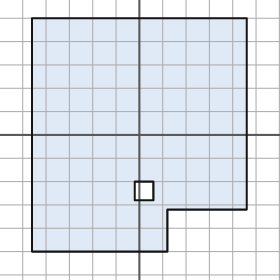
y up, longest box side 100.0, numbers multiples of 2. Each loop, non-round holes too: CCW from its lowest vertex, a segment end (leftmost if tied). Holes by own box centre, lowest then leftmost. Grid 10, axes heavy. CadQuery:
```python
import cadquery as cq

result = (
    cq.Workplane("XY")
    .moveTo(-46.0, -50.0)
    .lineTo(12.0, -50.0)
    .lineTo(12.0, -32.0)
    .lineTo(46.0, -32.0)
    .lineTo(46.0, 50.0)
    .lineTo(-46.0, 50.0)
    .close()
    .moveTo(-2.0, -28.0)
    .lineTo(6.0, -28.0)
    .lineTo(6.0, -20.0)
    .lineTo(-2.0, -20.0)
    .close()
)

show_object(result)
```